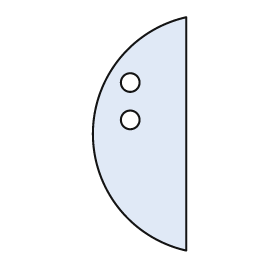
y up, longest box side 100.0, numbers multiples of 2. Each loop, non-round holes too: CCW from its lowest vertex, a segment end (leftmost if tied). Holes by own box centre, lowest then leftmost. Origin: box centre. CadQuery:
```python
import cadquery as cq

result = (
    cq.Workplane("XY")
    .moveTo(20.0, -50.0)
    .lineTo(20.0, 50.0)
    .threePointArc((-20.0, 0.0), (20.0, -50.0))
    .close()
    .moveTo(-4.0, 6.0)
    .circle(4.0)
    .moveTo(-4.0, 22.0)
    .circle(4.0)
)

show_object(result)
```